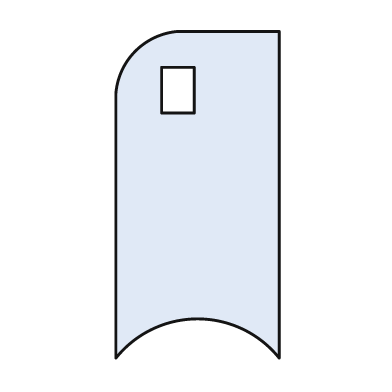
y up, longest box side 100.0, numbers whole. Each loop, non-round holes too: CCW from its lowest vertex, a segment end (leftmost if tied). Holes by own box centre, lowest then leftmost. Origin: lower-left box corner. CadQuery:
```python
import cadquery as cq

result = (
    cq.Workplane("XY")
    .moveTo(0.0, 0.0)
    .threePointArc((25.0, 12.0), (50.0, 0.0))
    .lineTo(50.0, 100.0)
    .lineTo(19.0, 100.0)
    .threePointArc((6.0, 94.0), (0.0, 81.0))
    .close()
    .moveTo(14.0, 75.0)
    .lineTo(24.0, 75.0)
    .lineTo(24.0, 89.0)
    .lineTo(14.0, 89.0)
    .close()
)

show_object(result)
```